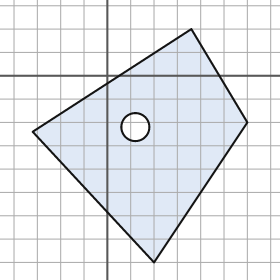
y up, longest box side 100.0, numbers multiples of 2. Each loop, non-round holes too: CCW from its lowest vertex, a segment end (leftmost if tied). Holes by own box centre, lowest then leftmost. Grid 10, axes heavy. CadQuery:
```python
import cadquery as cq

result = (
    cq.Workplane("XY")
    .moveTo(20.0, -80.0)
    .lineTo(60.0, -20.0)
    .lineTo(36.0, 20.0)
    .lineTo(-32.0, -24.0)
    .close()
    .moveTo(12.0, -22.0)
    .circle(6.0)
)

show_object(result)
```